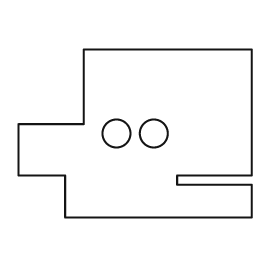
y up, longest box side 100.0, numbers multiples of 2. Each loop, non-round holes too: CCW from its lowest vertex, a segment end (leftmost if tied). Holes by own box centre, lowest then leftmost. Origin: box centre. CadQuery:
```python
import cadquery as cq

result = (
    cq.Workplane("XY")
    .moveTo(-30.0, -36.0)
    .lineTo(50.0, -36.0)
    .lineTo(50.0, -22.0)
    .lineTo(18.0, -22.0)
    .lineTo(18.0, -18.0)
    .lineTo(50.0, -18.0)
    .lineTo(50.0, 36.0)
    .lineTo(-22.0, 36.0)
    .lineTo(-22.0, 4.0)
    .lineTo(-50.0, 4.0)
    .lineTo(-50.0, -18.0)
    .lineTo(-30.0, -18.0)
    .close()
    .moveTo(-8.0, 0.0)
    .circle(6.0)
    .moveTo(8.0, 0.0)
    .circle(6.0)
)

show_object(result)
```